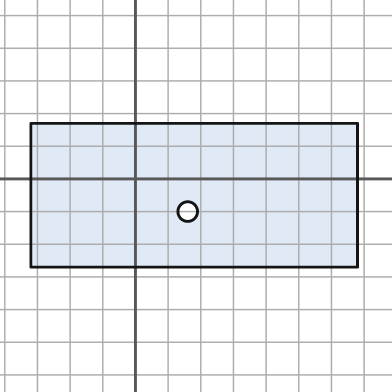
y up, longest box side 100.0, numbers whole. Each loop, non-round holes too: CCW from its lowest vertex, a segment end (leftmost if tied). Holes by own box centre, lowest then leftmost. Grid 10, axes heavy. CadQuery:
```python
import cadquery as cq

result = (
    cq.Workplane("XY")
    .moveTo(-32.0, -27.0)
    .lineTo(68.0, -27.0)
    .lineTo(68.0, 17.0)
    .lineTo(-32.0, 17.0)
    .close()
    .moveTo(16.0, -10.0)
    .circle(3.0)
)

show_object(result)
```